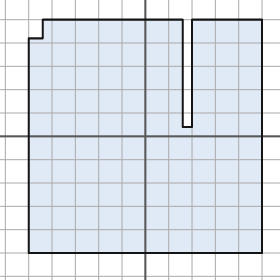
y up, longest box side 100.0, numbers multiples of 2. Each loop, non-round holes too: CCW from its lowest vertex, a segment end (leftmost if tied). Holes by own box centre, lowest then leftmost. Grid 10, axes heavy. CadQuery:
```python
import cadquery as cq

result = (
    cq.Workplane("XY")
    .moveTo(-50.0, -50.0)
    .lineTo(50.0, -50.0)
    .lineTo(50.0, 50.0)
    .lineTo(20.0, 50.0)
    .lineTo(20.0, 4.0)
    .lineTo(16.0, 4.0)
    .lineTo(16.0, 50.0)
    .lineTo(-44.0, 50.0)
    .lineTo(-44.0, 42.0)
    .lineTo(-50.0, 42.0)
    .close()
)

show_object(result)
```